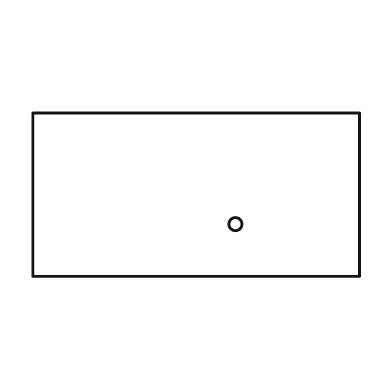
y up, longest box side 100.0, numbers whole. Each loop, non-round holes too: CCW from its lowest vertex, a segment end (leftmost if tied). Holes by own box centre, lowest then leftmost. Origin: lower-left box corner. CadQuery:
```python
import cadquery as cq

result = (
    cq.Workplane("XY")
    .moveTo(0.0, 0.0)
    .lineTo(100.0, 0.0)
    .lineTo(100.0, 50.0)
    .lineTo(0.0, 50.0)
    .close()
    .moveTo(62.0, 16.0)
    .circle(2.0)
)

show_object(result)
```